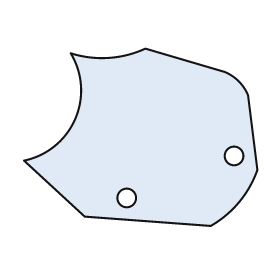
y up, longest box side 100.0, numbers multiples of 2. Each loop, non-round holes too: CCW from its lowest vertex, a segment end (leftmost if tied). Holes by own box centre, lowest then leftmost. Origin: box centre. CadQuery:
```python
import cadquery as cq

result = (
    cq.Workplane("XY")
    .moveTo(30.0, -38.0)
    .threePointArc((42.0, -28.0), (50.0, -14.0))
    .lineTo(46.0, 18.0)
    .threePointArc((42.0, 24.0), (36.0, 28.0))
    .lineTo(2.0, 38.0)
    .threePointArc((-14.0, 34.0), (-30.0, 36.0))
    .threePointArc((-28.0, 8.0), (-50.0, -10.0))
    .lineTo(-24.0, -34.0)
    .close()
    .moveTo(-6.0, -26.0)
    .circle(4.0)
    .moveTo(40.0, -8.0)
    .circle(4.0)
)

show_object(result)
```